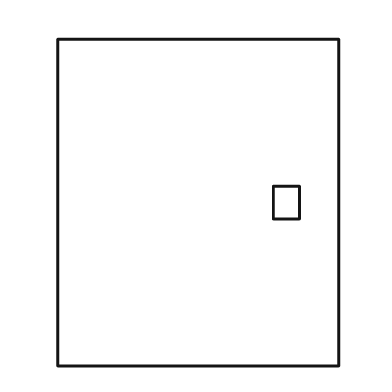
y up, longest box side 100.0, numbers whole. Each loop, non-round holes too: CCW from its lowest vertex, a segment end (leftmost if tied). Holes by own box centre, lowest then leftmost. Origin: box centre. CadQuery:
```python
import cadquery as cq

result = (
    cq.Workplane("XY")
    .moveTo(-43.0, -50.0)
    .lineTo(43.0, -50.0)
    .lineTo(43.0, 50.0)
    .lineTo(-43.0, 50.0)
    .close()
    .moveTo(23.0, -5.0)
    .lineTo(31.0, -5.0)
    .lineTo(31.0, 5.0)
    .lineTo(23.0, 5.0)
    .close()
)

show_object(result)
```